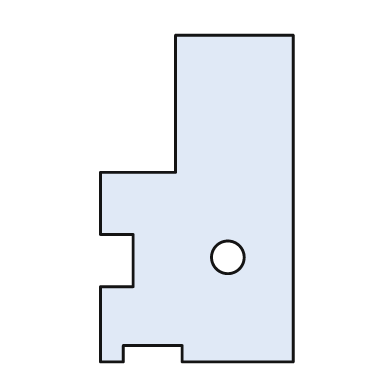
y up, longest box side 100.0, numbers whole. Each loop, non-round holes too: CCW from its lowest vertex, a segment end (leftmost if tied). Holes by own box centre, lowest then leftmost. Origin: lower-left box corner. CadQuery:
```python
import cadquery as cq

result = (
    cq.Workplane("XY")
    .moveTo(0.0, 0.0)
    .lineTo(7.0, 0.0)
    .lineTo(7.0, 5.0)
    .lineTo(25.0, 5.0)
    .lineTo(25.0, 0.0)
    .lineTo(59.0, 0.0)
    .lineTo(59.0, 100.0)
    .lineTo(23.0, 100.0)
    .lineTo(23.0, 58.0)
    .lineTo(0.0, 58.0)
    .lineTo(0.0, 39.0)
    .lineTo(10.0, 39.0)
    .lineTo(10.0, 23.0)
    .lineTo(0.0, 23.0)
    .close()
    .moveTo(39.0, 32.0)
    .circle(5.0)
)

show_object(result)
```